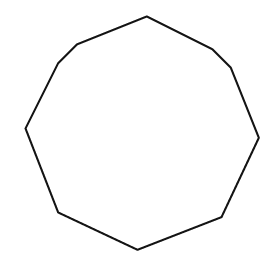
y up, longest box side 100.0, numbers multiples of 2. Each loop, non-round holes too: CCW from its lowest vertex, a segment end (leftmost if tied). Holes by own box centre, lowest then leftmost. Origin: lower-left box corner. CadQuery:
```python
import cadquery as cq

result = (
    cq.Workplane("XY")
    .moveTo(48.0, 0.0)
    .lineTo(84.0, 14.0)
    .lineTo(100.0, 48.0)
    .lineTo(88.0, 78.0)
    .lineTo(80.0, 86.0)
    .lineTo(52.0, 100.0)
    .lineTo(22.0, 88.0)
    .lineTo(14.0, 80.0)
    .lineTo(0.0, 52.0)
    .lineTo(14.0, 16.0)
    .close()
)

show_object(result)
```